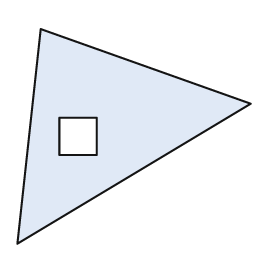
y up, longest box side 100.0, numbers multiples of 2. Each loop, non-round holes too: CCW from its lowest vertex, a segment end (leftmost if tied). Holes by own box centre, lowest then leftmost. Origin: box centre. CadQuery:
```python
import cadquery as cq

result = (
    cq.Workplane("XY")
    .moveTo(-50.0, -46.0)
    .lineTo(50.0, 14.0)
    .lineTo(-40.0, 46.0)
    .close()
    .moveTo(-32.0, -8.0)
    .lineTo(-16.0, -8.0)
    .lineTo(-16.0, 8.0)
    .lineTo(-32.0, 8.0)
    .close()
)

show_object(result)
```